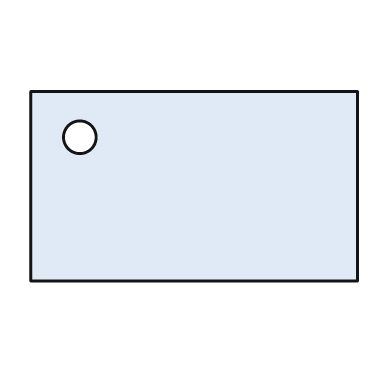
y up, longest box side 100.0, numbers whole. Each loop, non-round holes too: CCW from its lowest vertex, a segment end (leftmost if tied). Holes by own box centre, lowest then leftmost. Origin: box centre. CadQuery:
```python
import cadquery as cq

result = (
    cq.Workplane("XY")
    .moveTo(-50.0, -29.0)
    .lineTo(50.0, -29.0)
    .lineTo(50.0, 29.0)
    .lineTo(-50.0, 29.0)
    .close()
    .moveTo(-35.0, 15.0)
    .circle(5.0)
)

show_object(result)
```